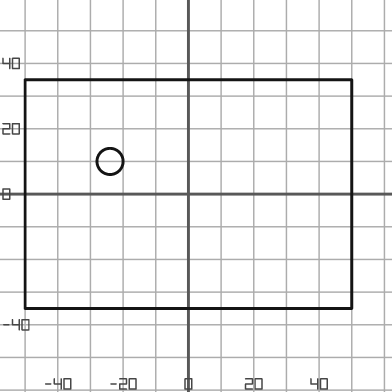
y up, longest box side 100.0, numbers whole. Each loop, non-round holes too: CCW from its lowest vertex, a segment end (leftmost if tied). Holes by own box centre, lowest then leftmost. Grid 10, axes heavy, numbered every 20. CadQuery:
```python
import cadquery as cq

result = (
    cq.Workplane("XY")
    .moveTo(-50.0, -35.0)
    .lineTo(50.0, -35.0)
    .lineTo(50.0, 35.0)
    .lineTo(-50.0, 35.0)
    .close()
    .moveTo(-24.0, 10.0)
    .circle(4.0)
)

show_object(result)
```